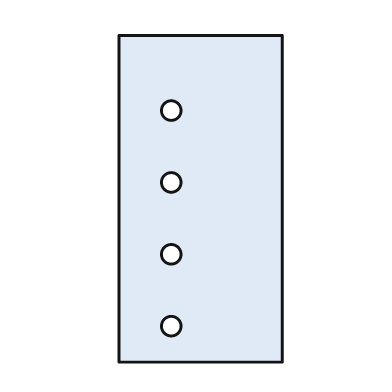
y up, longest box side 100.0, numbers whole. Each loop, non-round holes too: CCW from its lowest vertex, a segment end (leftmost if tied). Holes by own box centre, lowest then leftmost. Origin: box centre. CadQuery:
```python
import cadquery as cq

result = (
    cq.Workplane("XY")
    .moveTo(-25.0, -50.0)
    .lineTo(25.0, -50.0)
    .lineTo(25.0, 50.0)
    .lineTo(-25.0, 50.0)
    .close()
    .moveTo(-9.0, -39.0)
    .circle(3.0)
    .moveTo(-9.0, -17.0)
    .circle(3.0)
    .moveTo(-9.0, 5.0)
    .circle(3.0)
    .moveTo(-9.0, 27.0)
    .circle(3.0)
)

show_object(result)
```